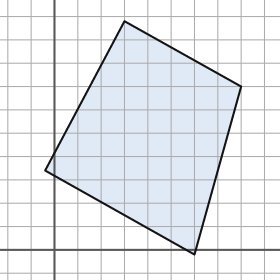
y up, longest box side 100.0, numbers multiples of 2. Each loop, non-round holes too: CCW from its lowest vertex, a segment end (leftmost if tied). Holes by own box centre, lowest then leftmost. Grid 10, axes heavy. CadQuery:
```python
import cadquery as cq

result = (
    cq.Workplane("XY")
    .moveTo(60.0, -2.0)
    .lineTo(80.0, 70.0)
    .lineTo(30.0, 98.0)
    .lineTo(-4.0, 34.0)
    .close()
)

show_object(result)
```